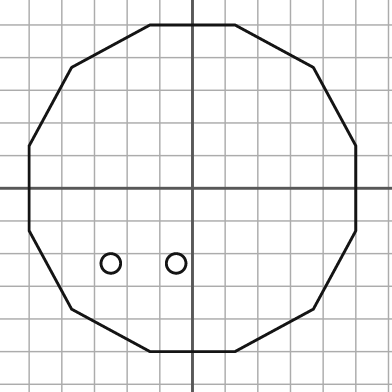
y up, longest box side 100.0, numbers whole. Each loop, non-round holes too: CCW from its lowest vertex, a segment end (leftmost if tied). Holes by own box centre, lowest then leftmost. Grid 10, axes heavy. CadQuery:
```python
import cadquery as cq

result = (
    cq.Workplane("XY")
    .moveTo(-13.0, -50.0)
    .lineTo(13.0, -50.0)
    .lineTo(37.0, -37.0)
    .lineTo(50.0, -13.0)
    .lineTo(50.0, 13.0)
    .lineTo(37.0, 37.0)
    .lineTo(13.0, 50.0)
    .lineTo(-13.0, 50.0)
    .lineTo(-37.0, 37.0)
    .lineTo(-50.0, 13.0)
    .lineTo(-50.0, -13.0)
    .lineTo(-37.0, -37.0)
    .close()
    .moveTo(-25.0, -23.0)
    .circle(3.0)
    .moveTo(-5.0, -23.0)
    .circle(3.0)
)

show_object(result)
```